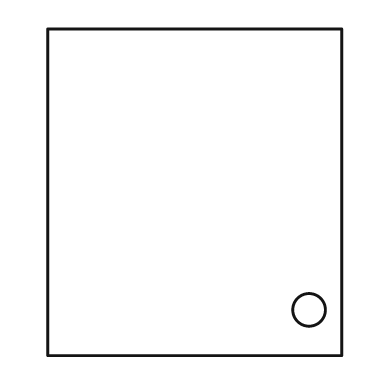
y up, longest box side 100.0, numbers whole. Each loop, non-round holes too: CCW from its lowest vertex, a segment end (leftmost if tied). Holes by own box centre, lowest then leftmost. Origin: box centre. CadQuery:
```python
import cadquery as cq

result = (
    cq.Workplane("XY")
    .moveTo(-45.0, -50.0)
    .lineTo(45.0, -50.0)
    .lineTo(45.0, 50.0)
    .lineTo(-45.0, 50.0)
    .close()
    .moveTo(35.0, -36.0)
    .circle(5.0)
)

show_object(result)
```